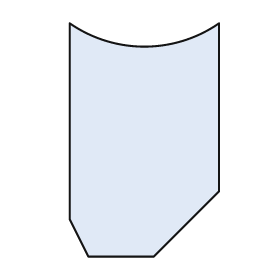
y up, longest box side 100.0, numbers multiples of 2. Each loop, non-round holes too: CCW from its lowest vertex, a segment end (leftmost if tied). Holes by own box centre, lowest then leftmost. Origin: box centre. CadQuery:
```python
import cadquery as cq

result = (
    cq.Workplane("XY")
    .moveTo(-24.0, -50.0)
    .lineTo(4.0, -50.0)
    .lineTo(32.0, -22.0)
    .lineTo(32.0, 50.0)
    .threePointArc((0.0, 40.0), (-32.0, 50.0))
    .lineTo(-32.0, -34.0)
    .close()
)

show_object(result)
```